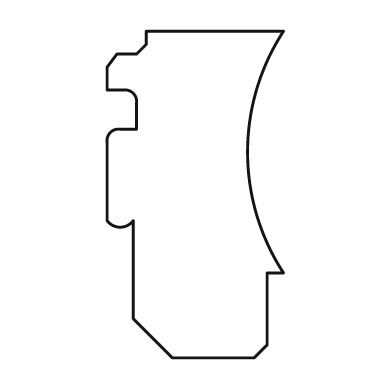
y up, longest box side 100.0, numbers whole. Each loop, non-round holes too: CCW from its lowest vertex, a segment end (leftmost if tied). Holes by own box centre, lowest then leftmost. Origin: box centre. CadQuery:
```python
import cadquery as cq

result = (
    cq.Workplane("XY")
    .moveTo(-7.0, -50.0)
    .lineTo(18.0, -50.0)
    .lineTo(22.0, -46.0)
    .lineTo(22.0, -24.0)
    .lineTo(27.0, -24.0)
    .threePointArc((16.0, 13.0), (27.0, 50.0))
    .lineTo(-15.0, 50.0)
    .lineTo(-15.0, 46.0)
    .lineTo(-18.0, 43.0)
    .lineTo(-24.0, 43.0)
    .lineTo(-27.0, 39.0)
    .lineTo(-27.0, 32.0)
    .lineTo(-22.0, 32.0)
    .threePointArc((-19.0, 31.0), (-18.0, 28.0))
    .lineTo(-18.0, 20.0)
    .lineTo(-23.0, 20.0)
    .threePointArc((-26.0, 19.0), (-27.0, 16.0))
    .lineTo(-27.0, -8.0)
    .threePointArc((-23.0, -10.0), (-19.0, -8.0))
    .lineTo(-19.0, -38.0)
    .close()
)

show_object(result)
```